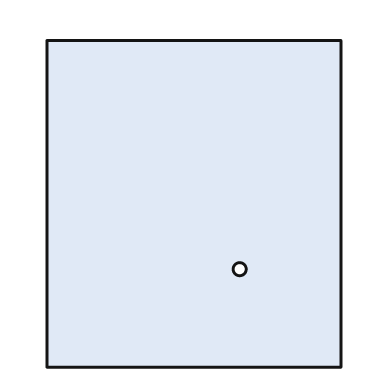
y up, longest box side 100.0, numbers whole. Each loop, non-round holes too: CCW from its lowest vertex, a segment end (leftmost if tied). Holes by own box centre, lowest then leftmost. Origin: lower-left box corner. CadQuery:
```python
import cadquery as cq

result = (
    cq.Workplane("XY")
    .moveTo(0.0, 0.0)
    .lineTo(90.0, 0.0)
    .lineTo(90.0, 100.0)
    .lineTo(0.0, 100.0)
    .close()
    .moveTo(59.0, 30.0)
    .circle(2.0)
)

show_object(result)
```